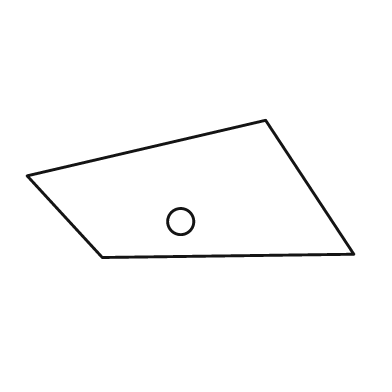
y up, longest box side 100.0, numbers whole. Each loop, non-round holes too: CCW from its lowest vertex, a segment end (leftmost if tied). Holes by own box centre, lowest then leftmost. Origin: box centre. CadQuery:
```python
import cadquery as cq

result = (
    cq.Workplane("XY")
    .moveTo(-27.0, -21.0)
    .lineTo(50.0, -20.0)
    .lineTo(23.0, 21.0)
    .lineTo(-50.0, 4.0)
    .close()
    .moveTo(-3.0, -10.0)
    .circle(4.0)
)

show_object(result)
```